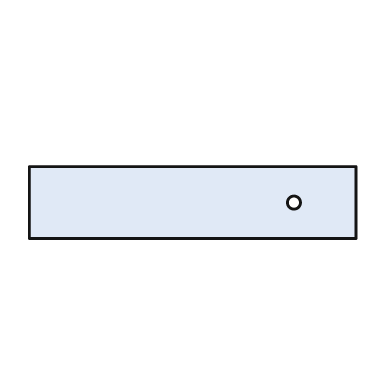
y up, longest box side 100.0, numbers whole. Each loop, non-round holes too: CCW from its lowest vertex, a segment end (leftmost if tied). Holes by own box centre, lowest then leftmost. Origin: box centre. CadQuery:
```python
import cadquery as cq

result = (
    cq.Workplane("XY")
    .moveTo(-50.0, -11.0)
    .lineTo(50.0, -11.0)
    .lineTo(50.0, 11.0)
    .lineTo(-50.0, 11.0)
    .close()
    .moveTo(31.0, 0.0)
    .circle(2.0)
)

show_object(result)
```